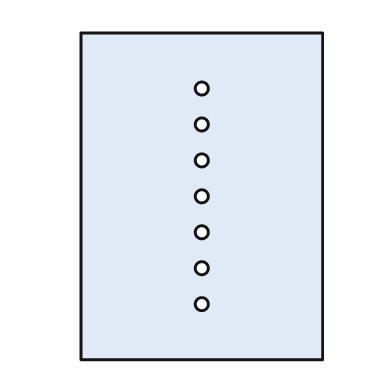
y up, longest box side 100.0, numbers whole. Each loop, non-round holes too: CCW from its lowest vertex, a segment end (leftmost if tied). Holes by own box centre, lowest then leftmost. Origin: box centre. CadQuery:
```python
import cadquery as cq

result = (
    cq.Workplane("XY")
    .moveTo(-37.0, -50.0)
    .lineTo(37.0, -50.0)
    .lineTo(37.0, 50.0)
    .lineTo(-37.0, 50.0)
    .close()
    .moveTo(0.0, -33.0)
    .circle(2.0)
    .moveTo(0.0, -22.0)
    .circle(2.0)
    .moveTo(0.0, -11.0)
    .circle(2.0)
    .moveTo(0.0, 0.0)
    .circle(2.0)
    .moveTo(0.0, 11.0)
    .circle(2.0)
    .moveTo(0.0, 22.0)
    .circle(2.0)
    .moveTo(0.0, 33.0)
    .circle(2.0)
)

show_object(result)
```